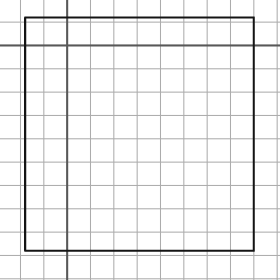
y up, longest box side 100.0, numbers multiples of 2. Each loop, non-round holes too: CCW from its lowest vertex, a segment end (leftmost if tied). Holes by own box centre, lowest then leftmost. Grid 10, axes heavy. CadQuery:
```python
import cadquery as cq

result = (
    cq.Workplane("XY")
    .moveTo(-18.0, -88.0)
    .lineTo(80.0, -88.0)
    .lineTo(80.0, 12.0)
    .lineTo(-18.0, 12.0)
    .close()
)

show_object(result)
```